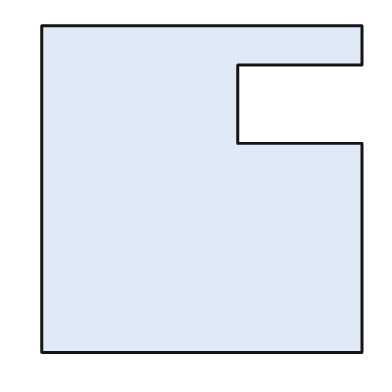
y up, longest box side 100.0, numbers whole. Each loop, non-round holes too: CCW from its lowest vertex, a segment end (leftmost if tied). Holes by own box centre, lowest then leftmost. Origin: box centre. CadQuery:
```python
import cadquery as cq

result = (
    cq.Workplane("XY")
    .moveTo(-49.0, -50.0)
    .lineTo(49.0, -50.0)
    .lineTo(49.0, 14.0)
    .lineTo(11.0, 14.0)
    .lineTo(11.0, 38.0)
    .lineTo(49.0, 38.0)
    .lineTo(49.0, 50.0)
    .lineTo(-49.0, 50.0)
    .close()
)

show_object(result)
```